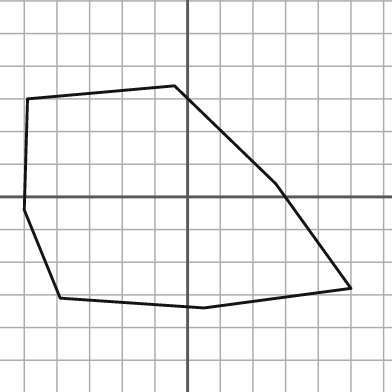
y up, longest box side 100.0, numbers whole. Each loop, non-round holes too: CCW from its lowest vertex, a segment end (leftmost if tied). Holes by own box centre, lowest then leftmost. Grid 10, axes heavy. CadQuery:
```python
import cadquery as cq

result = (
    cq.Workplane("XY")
    .moveTo(5.0, -34.0)
    .lineTo(50.0, -28.0)
    .lineTo(27.0, 4.0)
    .lineTo(-4.0, 34.0)
    .lineTo(-49.0, 30.0)
    .lineTo(-50.0, -4.0)
    .lineTo(-39.0, -31.0)
    .close()
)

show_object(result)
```